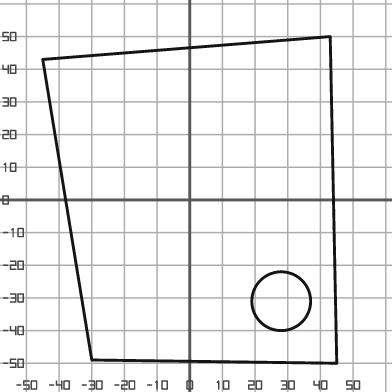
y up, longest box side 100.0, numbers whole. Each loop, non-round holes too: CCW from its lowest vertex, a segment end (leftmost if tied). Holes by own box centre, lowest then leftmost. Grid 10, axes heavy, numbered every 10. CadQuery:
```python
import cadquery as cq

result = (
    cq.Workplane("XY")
    .moveTo(45.0, -50.0)
    .lineTo(43.0, 50.0)
    .lineTo(-45.0, 43.0)
    .lineTo(-30.0, -49.0)
    .close()
    .moveTo(28.0, -31.0)
    .circle(9.0)
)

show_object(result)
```